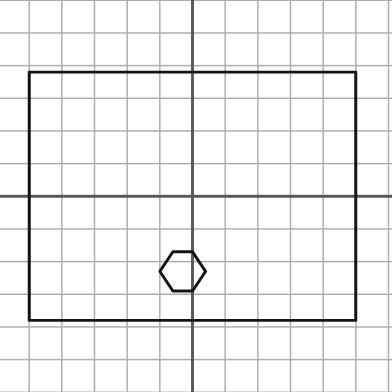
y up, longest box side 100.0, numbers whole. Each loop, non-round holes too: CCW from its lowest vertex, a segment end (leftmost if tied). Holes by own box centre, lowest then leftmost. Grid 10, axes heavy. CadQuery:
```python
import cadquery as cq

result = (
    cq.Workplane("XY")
    .moveTo(-50.0, -38.0)
    .lineTo(50.0, -38.0)
    .lineTo(50.0, 38.0)
    .lineTo(-50.0, 38.0)
    .close()
    .moveTo(-6.0, -29.0)
    .lineTo(0.0, -29.0)
    .lineTo(4.0, -23.0)
    .lineTo(0.0, -17.0)
    .lineTo(-6.0, -17.0)
    .lineTo(-10.0, -23.0)
    .close()
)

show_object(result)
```